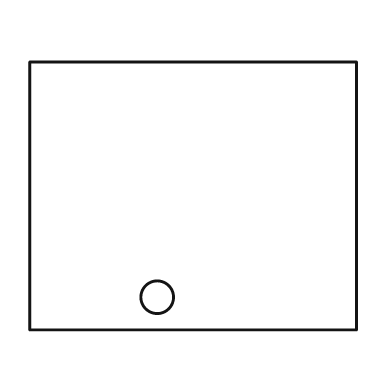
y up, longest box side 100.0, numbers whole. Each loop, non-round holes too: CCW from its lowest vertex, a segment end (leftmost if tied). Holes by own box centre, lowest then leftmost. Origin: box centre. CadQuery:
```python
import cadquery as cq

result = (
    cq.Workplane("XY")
    .moveTo(-50.0, -41.0)
    .lineTo(50.0, -41.0)
    .lineTo(50.0, 41.0)
    .lineTo(-50.0, 41.0)
    .close()
    .moveTo(-11.0, -31.0)
    .circle(5.0)
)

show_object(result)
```